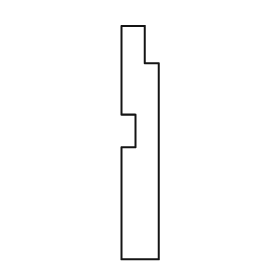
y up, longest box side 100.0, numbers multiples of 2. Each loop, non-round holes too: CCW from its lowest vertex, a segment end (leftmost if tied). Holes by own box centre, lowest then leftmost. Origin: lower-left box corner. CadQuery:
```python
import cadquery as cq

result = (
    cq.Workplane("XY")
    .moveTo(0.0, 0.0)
    .lineTo(16.0, 0.0)
    .lineTo(16.0, 84.0)
    .lineTo(10.0, 84.0)
    .lineTo(10.0, 100.0)
    .lineTo(0.0, 100.0)
    .lineTo(0.0, 62.0)
    .lineTo(6.0, 62.0)
    .lineTo(6.0, 48.0)
    .lineTo(0.0, 48.0)
    .close()
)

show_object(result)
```